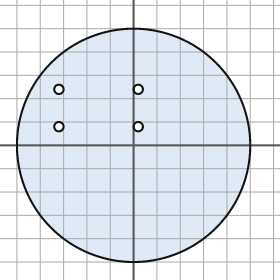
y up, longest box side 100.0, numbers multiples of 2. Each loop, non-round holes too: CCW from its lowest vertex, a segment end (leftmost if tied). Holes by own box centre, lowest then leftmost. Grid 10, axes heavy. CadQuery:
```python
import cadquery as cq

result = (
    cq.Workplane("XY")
    .moveTo(0.0, 0.0)
    .circle(50.0)
    .moveTo(-32.0, 8.0)
    .circle(2.0)
    .moveTo(2.0, 8.0)
    .circle(2.0)
    .moveTo(-32.0, 24.0)
    .circle(2.0)
    .moveTo(2.0, 24.0)
    .circle(2.0)
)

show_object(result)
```